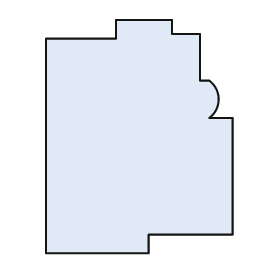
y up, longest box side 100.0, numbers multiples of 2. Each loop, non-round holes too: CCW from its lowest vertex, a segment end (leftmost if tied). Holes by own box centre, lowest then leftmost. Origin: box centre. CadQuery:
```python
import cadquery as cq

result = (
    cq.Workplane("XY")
    .moveTo(-40.0, -50.0)
    .lineTo(4.0, -50.0)
    .lineTo(4.0, -42.0)
    .lineTo(40.0, -42.0)
    .lineTo(40.0, 8.0)
    .lineTo(30.0, 8.0)
    .threePointArc((34.0, 16.0), (30.0, 24.0))
    .lineTo(26.0, 24.0)
    .lineTo(26.0, 44.0)
    .lineTo(14.0, 44.0)
    .lineTo(14.0, 50.0)
    .lineTo(-10.0, 50.0)
    .lineTo(-10.0, 42.0)
    .lineTo(-40.0, 42.0)
    .close()
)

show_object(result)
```